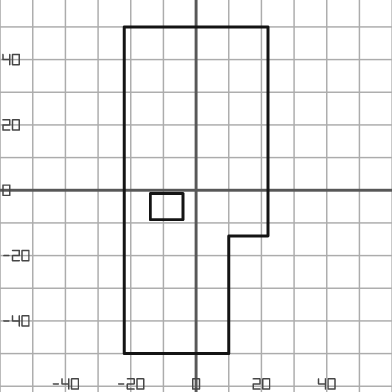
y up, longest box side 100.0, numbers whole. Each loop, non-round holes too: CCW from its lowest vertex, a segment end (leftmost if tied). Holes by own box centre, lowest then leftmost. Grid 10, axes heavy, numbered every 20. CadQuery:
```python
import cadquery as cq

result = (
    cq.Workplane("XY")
    .moveTo(-22.0, -50.0)
    .lineTo(10.0, -50.0)
    .lineTo(10.0, -14.0)
    .lineTo(22.0, -14.0)
    .lineTo(22.0, 50.0)
    .lineTo(-22.0, 50.0)
    .close()
    .moveTo(-14.0, -9.0)
    .lineTo(-4.0, -9.0)
    .lineTo(-4.0, -1.0)
    .lineTo(-14.0, -1.0)
    .close()
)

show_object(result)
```